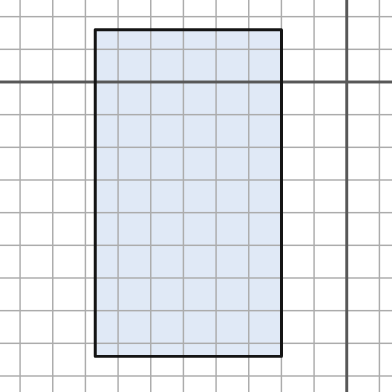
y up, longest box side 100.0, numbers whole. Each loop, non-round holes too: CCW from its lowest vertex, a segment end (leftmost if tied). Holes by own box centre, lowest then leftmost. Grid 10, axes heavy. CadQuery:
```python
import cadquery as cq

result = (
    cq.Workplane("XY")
    .moveTo(-77.0, -84.0)
    .lineTo(-20.0, -84.0)
    .lineTo(-20.0, 16.0)
    .lineTo(-77.0, 16.0)
    .close()
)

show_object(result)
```